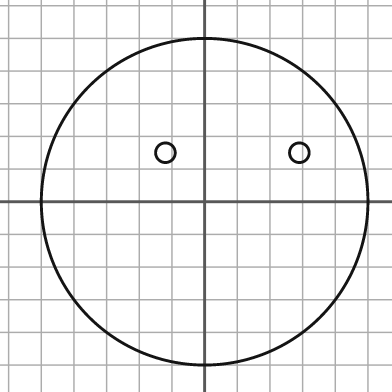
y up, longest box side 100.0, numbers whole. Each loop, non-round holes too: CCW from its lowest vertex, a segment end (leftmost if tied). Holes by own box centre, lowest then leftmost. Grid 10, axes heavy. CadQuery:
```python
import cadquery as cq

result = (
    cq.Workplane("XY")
    .moveTo(0.0, 0.0)
    .circle(50.0)
    .moveTo(-12.0, 15.0)
    .circle(3.0)
    .moveTo(29.0, 15.0)
    .circle(3.0)
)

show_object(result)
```